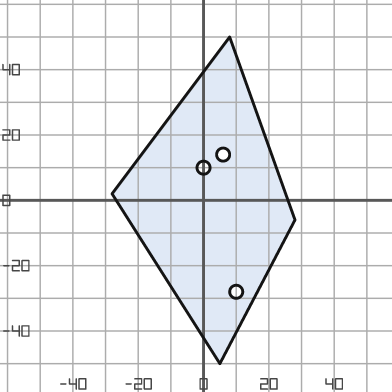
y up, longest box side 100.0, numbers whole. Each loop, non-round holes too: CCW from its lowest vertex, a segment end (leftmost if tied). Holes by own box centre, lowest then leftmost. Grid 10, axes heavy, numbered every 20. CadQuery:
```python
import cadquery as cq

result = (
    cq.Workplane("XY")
    .moveTo(5.0, -50.0)
    .lineTo(28.0, -6.0)
    .lineTo(8.0, 50.0)
    .lineTo(-28.0, 2.0)
    .close()
    .moveTo(10.0, -28.0)
    .circle(2.0)
    .moveTo(0.0, 10.0)
    .circle(2.0)
    .moveTo(6.0, 14.0)
    .circle(2.0)
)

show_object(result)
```